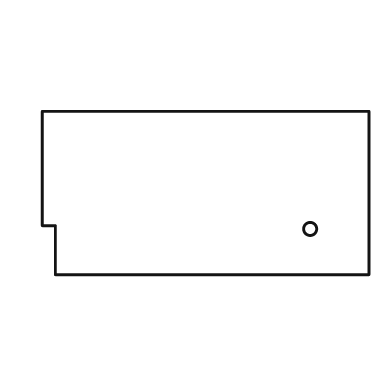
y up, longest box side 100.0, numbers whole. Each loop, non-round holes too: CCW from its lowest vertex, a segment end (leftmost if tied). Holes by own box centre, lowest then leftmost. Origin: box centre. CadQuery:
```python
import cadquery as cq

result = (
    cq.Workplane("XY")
    .moveTo(-46.0, -25.0)
    .lineTo(50.0, -25.0)
    .lineTo(50.0, 25.0)
    .lineTo(-50.0, 25.0)
    .lineTo(-50.0, -10.0)
    .lineTo(-46.0, -10.0)
    .close()
    .moveTo(32.0, -11.0)
    .circle(2.0)
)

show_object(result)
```